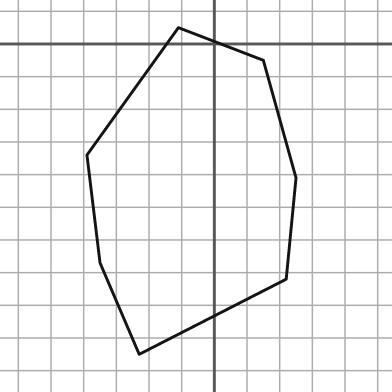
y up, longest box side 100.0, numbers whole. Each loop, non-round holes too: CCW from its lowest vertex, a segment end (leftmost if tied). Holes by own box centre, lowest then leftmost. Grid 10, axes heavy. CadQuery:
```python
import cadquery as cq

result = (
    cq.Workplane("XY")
    .moveTo(-23.0, -95.0)
    .lineTo(22.0, -72.0)
    .lineTo(25.0, -41.0)
    .lineTo(15.0, -5.0)
    .lineTo(-11.0, 5.0)
    .lineTo(-39.0, -34.0)
    .lineTo(-35.0, -67.0)
    .close()
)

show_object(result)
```